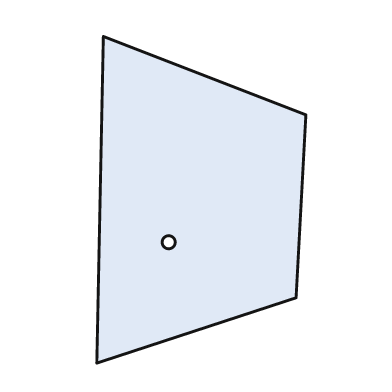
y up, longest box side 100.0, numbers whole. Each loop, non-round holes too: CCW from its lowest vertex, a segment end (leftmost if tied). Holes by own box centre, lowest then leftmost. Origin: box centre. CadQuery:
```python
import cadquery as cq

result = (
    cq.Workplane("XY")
    .moveTo(-32.0, -50.0)
    .lineTo(29.0, -30.0)
    .lineTo(32.0, 26.0)
    .lineTo(-30.0, 50.0)
    .close()
    .moveTo(-10.0, -13.0)
    .circle(2.0)
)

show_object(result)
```